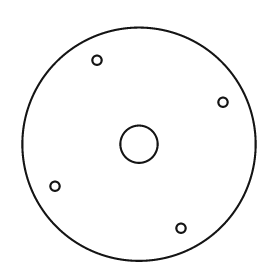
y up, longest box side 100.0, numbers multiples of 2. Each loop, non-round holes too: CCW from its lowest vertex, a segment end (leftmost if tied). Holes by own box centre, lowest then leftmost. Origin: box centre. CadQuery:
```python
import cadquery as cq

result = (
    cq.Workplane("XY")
    .moveTo(0.0, 0.0)
    .circle(50.0)
    .moveTo(18.0, -36.0)
    .circle(2.0)
    .moveTo(-36.0, -18.0)
    .circle(2.0)
    .moveTo(0.0, 0.0)
    .circle(8.0)
    .moveTo(36.0, 18.0)
    .circle(2.0)
    .moveTo(-18.0, 36.0)
    .circle(2.0)
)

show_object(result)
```